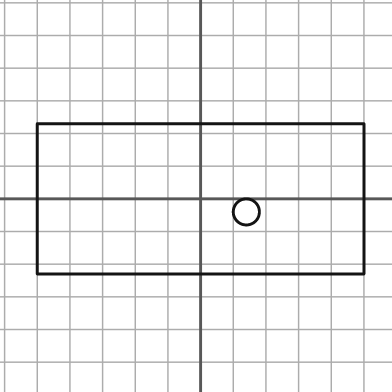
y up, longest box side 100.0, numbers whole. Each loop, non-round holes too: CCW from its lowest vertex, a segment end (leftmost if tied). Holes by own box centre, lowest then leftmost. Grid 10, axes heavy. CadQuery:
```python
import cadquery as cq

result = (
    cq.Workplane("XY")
    .moveTo(-50.0, -23.0)
    .lineTo(50.0, -23.0)
    .lineTo(50.0, 23.0)
    .lineTo(-50.0, 23.0)
    .close()
    .moveTo(14.0, -4.0)
    .circle(4.0)
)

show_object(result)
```